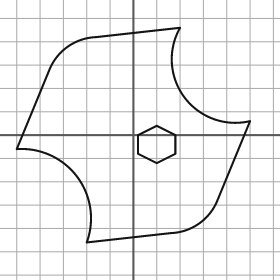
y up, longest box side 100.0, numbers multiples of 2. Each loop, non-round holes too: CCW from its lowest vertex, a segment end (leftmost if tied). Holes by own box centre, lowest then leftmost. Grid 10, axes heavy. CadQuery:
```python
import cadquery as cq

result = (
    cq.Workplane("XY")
    .moveTo(-20.0, -46.0)
    .lineTo(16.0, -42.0)
    .threePointArc((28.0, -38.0), (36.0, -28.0))
    .lineTo(50.0, 6.0)
    .threePointArc((22.0, 16.0), (20.0, 46.0))
    .lineTo(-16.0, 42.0)
    .threePointArc((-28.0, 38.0), (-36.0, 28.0))
    .lineTo(-50.0, -6.0)
    .threePointArc((-24.0, -18.0), (-20.0, -46.0))
    .close()
    .moveTo(10.0, -12.0)
    .lineTo(18.0, -8.0)
    .lineTo(18.0, 0.0)
    .lineTo(10.0, 4.0)
    .lineTo(2.0, 0.0)
    .lineTo(2.0, -8.0)
    .close()
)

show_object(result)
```